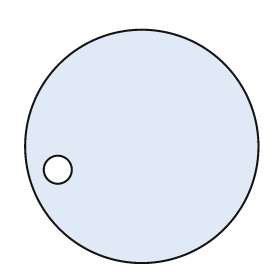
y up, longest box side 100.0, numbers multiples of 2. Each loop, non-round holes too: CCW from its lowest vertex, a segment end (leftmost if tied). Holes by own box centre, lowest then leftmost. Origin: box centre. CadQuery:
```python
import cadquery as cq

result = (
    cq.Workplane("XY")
    .moveTo(0.0, 0.0)
    .circle(50.0)
    .moveTo(-36.0, -10.0)
    .circle(6.0)
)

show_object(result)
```